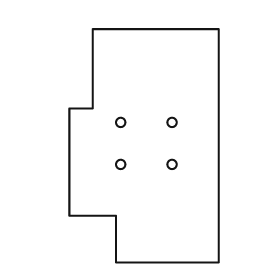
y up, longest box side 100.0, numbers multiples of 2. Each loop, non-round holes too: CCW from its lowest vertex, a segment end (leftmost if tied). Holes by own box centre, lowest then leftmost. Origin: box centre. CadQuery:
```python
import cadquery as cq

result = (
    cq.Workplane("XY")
    .moveTo(-12.0, -50.0)
    .lineTo(32.0, -50.0)
    .lineTo(32.0, 50.0)
    .lineTo(-22.0, 50.0)
    .lineTo(-22.0, 16.0)
    .lineTo(-32.0, 16.0)
    .lineTo(-32.0, -30.0)
    .lineTo(-12.0, -30.0)
    .close()
    .moveTo(-10.0, -8.0)
    .circle(2.0)
    .moveTo(12.0, -8.0)
    .circle(2.0)
    .moveTo(-10.0, 10.0)
    .circle(2.0)
    .moveTo(12.0, 10.0)
    .circle(2.0)
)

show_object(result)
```